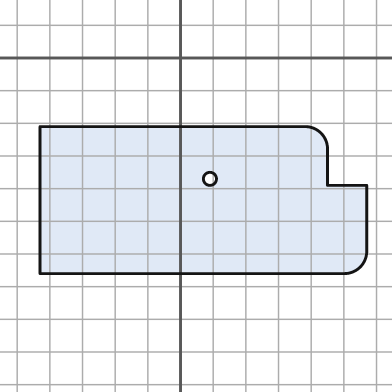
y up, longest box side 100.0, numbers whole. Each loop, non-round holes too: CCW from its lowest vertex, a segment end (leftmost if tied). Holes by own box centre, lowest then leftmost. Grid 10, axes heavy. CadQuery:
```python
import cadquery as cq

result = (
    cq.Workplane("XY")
    .moveTo(-43.0, -66.0)
    .lineTo(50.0, -66.0)
    .threePointArc((55.0, -64.0), (57.0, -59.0))
    .lineTo(57.0, -39.0)
    .lineTo(45.0, -39.0)
    .lineTo(45.0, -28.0)
    .threePointArc((43.0, -23.0), (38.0, -21.0))
    .lineTo(-43.0, -21.0)
    .close()
    .moveTo(9.0, -37.0)
    .circle(2.0)
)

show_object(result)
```